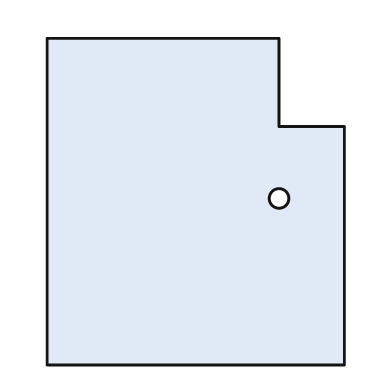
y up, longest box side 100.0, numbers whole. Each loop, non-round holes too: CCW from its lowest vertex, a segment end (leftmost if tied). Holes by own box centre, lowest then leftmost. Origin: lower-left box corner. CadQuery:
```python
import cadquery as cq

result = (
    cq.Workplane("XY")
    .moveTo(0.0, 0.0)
    .lineTo(91.0, 0.0)
    .lineTo(91.0, 73.0)
    .lineTo(71.0, 73.0)
    .lineTo(71.0, 100.0)
    .lineTo(0.0, 100.0)
    .close()
    .moveTo(71.0, 51.0)
    .circle(3.0)
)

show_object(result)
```